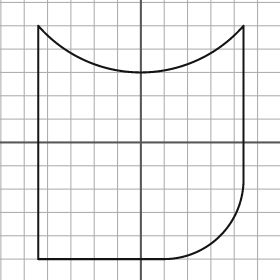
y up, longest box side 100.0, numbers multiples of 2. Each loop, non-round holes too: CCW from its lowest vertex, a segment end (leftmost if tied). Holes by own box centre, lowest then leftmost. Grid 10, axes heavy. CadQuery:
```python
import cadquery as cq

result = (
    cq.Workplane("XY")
    .moveTo(-44.0, -50.0)
    .lineTo(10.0, -50.0)
    .threePointArc((34.0, -40.0), (44.0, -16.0))
    .lineTo(44.0, 50.0)
    .threePointArc((0.0, 30.0), (-44.0, 50.0))
    .close()
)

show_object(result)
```